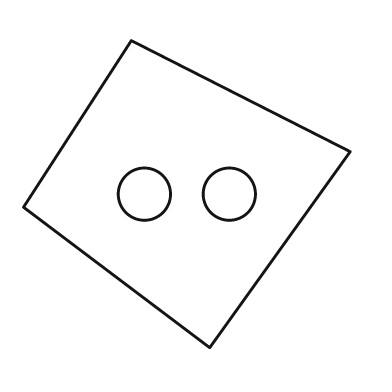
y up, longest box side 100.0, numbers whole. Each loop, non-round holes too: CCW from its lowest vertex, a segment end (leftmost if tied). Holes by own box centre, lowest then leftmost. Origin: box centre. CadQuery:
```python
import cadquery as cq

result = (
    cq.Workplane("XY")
    .moveTo(7.0, -47.0)
    .lineTo(50.0, 13.0)
    .lineTo(-17.0, 47.0)
    .lineTo(-50.0, -4.0)
    .close()
    .moveTo(-13.0, 0.0)
    .circle(8.0)
    .moveTo(13.0, 0.0)
    .circle(8.0)
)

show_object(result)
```